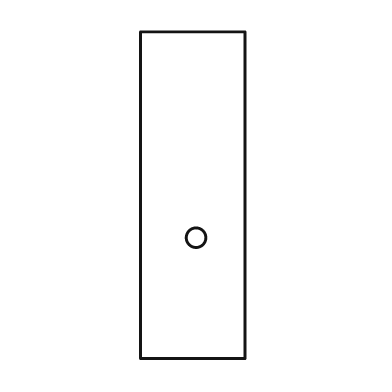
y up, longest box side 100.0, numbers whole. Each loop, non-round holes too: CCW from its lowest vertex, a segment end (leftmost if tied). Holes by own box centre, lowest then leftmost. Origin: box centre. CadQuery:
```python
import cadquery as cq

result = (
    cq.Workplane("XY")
    .moveTo(-16.0, -50.0)
    .lineTo(16.0, -50.0)
    .lineTo(16.0, 50.0)
    .lineTo(-16.0, 50.0)
    .close()
    .moveTo(1.0, -13.0)
    .circle(3.0)
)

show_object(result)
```